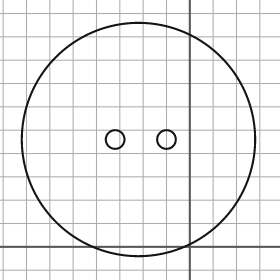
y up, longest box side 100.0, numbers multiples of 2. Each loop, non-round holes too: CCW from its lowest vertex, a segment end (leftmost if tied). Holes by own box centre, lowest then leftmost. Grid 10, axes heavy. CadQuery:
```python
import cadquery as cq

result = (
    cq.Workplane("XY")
    .moveTo(-22.0, 46.0)
    .circle(50.0)
    .moveTo(-32.0, 46.0)
    .circle(4.0)
    .moveTo(-10.0, 46.0)
    .circle(4.0)
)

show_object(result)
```